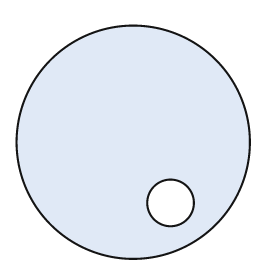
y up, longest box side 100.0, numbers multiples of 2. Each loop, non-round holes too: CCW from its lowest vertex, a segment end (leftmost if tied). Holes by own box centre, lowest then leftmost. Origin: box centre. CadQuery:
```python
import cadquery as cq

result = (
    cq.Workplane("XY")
    .moveTo(0.0, 0.0)
    .circle(50.0)
    .moveTo(16.0, -26.0)
    .circle(10.0)
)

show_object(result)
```